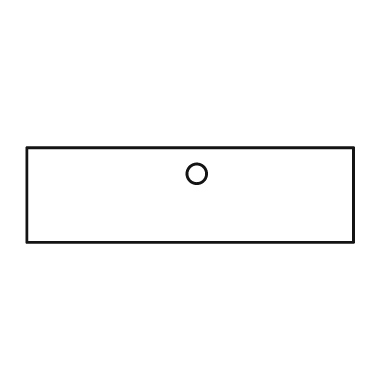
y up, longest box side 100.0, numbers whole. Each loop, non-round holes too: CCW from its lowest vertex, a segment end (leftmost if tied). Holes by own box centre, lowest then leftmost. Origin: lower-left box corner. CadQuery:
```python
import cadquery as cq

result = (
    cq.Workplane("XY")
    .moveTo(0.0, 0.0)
    .lineTo(100.0, 0.0)
    .lineTo(100.0, 29.0)
    .lineTo(0.0, 29.0)
    .close()
    .moveTo(52.0, 21.0)
    .circle(3.0)
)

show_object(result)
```